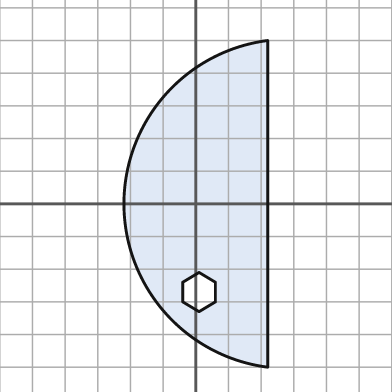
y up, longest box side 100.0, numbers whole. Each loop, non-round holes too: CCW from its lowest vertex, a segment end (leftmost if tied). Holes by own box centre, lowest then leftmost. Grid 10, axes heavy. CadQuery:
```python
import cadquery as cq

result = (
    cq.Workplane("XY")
    .moveTo(22.0, -50.0)
    .lineTo(22.0, 50.0)
    .threePointArc((-22.0, 0.0), (22.0, -50.0))
    .close()
    .moveTo(1.0, -33.0)
    .lineTo(6.0, -30.0)
    .lineTo(6.0, -24.0)
    .lineTo(1.0, -21.0)
    .lineTo(-4.0, -24.0)
    .lineTo(-4.0, -30.0)
    .close()
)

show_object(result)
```